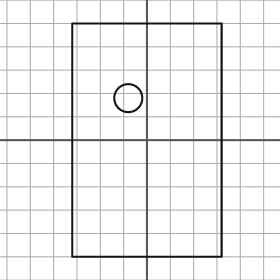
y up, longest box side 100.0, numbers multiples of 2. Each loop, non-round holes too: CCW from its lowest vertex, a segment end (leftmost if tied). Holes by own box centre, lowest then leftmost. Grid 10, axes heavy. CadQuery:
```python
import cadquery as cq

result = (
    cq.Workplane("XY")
    .moveTo(-32.0, -50.0)
    .lineTo(32.0, -50.0)
    .lineTo(32.0, 50.0)
    .lineTo(-32.0, 50.0)
    .close()
    .moveTo(-8.0, 18.0)
    .circle(6.0)
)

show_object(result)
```